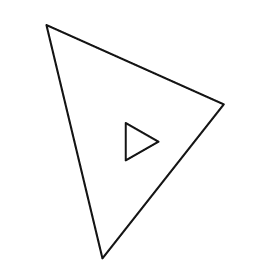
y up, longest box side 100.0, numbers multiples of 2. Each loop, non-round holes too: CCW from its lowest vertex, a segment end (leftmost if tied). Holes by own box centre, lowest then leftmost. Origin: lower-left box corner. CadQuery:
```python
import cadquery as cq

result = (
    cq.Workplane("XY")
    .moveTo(24.0, 0.0)
    .lineTo(76.0, 66.0)
    .lineTo(0.0, 100.0)
    .close()
    .moveTo(34.0, 42.0)
    .lineTo(48.0, 50.0)
    .lineTo(34.0, 58.0)
    .close()
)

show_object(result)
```